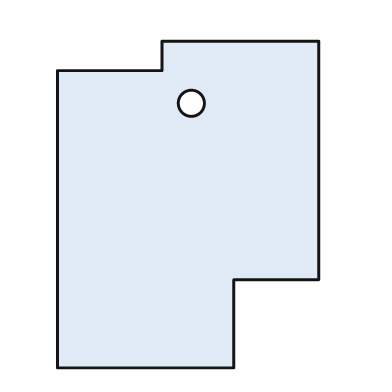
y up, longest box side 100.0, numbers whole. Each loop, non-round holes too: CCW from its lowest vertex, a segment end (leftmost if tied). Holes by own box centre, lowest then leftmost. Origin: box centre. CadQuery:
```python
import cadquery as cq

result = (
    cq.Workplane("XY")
    .moveTo(-40.0, -50.0)
    .lineTo(14.0, -50.0)
    .lineTo(14.0, -23.0)
    .lineTo(40.0, -23.0)
    .lineTo(40.0, 50.0)
    .lineTo(-8.0, 50.0)
    .lineTo(-8.0, 41.0)
    .lineTo(-40.0, 41.0)
    .close()
    .moveTo(1.0, 31.0)
    .circle(4.0)
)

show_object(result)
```